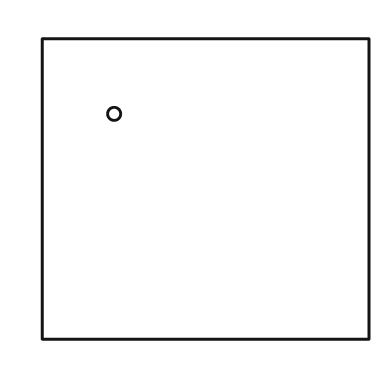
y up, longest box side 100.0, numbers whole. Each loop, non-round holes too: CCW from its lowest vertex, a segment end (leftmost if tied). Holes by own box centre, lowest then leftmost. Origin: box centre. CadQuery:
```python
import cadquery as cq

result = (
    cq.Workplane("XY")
    .moveTo(-50.0, -46.0)
    .lineTo(50.0, -46.0)
    .lineTo(50.0, 46.0)
    .lineTo(-50.0, 46.0)
    .close()
    .moveTo(-28.0, 23.0)
    .circle(2.0)
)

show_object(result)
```